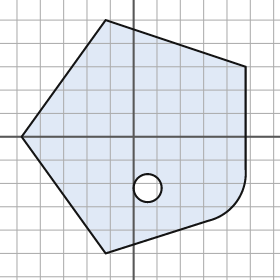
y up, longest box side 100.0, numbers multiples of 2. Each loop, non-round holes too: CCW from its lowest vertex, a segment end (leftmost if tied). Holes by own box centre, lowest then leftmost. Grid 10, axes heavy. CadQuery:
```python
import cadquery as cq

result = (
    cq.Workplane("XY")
    .moveTo(-12.0, -50.0)
    .lineTo(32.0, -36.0)
    .threePointArc((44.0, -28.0), (48.0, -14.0))
    .lineTo(48.0, 30.0)
    .lineTo(-12.0, 50.0)
    .lineTo(-48.0, 0.0)
    .close()
    .moveTo(6.0, -22.0)
    .circle(6.0)
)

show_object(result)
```